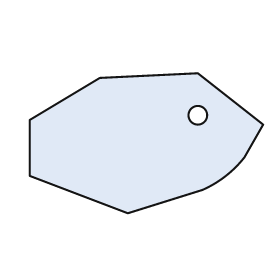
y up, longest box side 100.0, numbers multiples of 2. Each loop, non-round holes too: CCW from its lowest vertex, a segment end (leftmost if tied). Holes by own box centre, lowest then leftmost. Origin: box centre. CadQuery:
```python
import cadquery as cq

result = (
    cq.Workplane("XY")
    .moveTo(-8.0, -30.0)
    .lineTo(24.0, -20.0)
    .threePointArc((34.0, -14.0), (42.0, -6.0))
    .lineTo(50.0, 8.0)
    .lineTo(22.0, 30.0)
    .lineTo(-20.0, 28.0)
    .lineTo(-50.0, 10.0)
    .lineTo(-50.0, -14.0)
    .close()
    .moveTo(22.0, 12.0)
    .circle(4.0)
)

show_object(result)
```